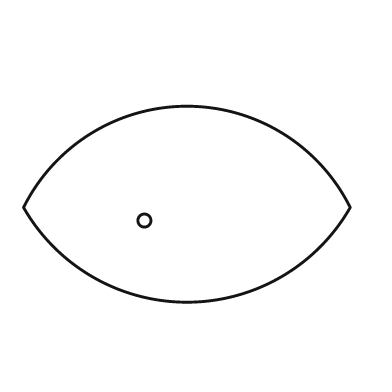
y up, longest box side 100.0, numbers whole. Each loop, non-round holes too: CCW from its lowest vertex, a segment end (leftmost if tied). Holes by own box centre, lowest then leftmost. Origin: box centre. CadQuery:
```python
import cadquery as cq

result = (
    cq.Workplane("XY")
    .moveTo(-50.0, -1.0)
    .threePointArc((0.0, -30.0), (50.0, -1.0))
    .threePointArc((0.0, 30.0), (-50.0, -1.0))
    .close()
    .moveTo(-13.0, -5.0)
    .circle(2.0)
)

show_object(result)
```